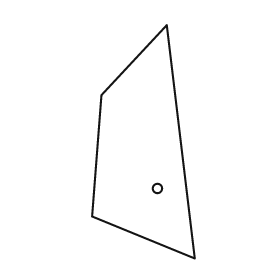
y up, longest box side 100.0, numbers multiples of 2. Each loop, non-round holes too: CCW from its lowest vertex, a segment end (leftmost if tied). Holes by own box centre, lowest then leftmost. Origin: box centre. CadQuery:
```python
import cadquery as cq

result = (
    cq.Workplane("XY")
    .moveTo(22.0, -50.0)
    .lineTo(10.0, 50.0)
    .lineTo(-18.0, 20.0)
    .lineTo(-22.0, -32.0)
    .close()
    .moveTo(6.0, -20.0)
    .circle(2.0)
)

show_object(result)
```